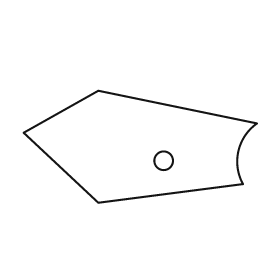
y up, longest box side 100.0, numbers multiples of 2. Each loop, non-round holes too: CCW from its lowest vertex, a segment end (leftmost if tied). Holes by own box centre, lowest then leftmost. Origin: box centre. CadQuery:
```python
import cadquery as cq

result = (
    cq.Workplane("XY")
    .moveTo(-18.0, -24.0)
    .lineTo(44.0, -16.0)
    .threePointArc((42.0, -2.0), (50.0, 10.0))
    .lineTo(-18.0, 24.0)
    .lineTo(-50.0, 6.0)
    .close()
    .moveTo(10.0, -6.0)
    .circle(4.0)
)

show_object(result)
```